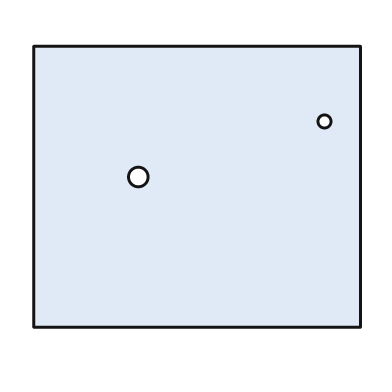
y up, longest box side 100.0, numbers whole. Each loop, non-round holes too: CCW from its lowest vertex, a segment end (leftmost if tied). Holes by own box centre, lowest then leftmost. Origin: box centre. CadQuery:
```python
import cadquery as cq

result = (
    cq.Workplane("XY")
    .moveTo(-50.0, -43.0)
    .lineTo(50.0, -43.0)
    .lineTo(50.0, 43.0)
    .lineTo(-50.0, 43.0)
    .close()
    .moveTo(-18.0, 3.0)
    .circle(3.0)
    .moveTo(39.0, 20.0)
    .circle(2.0)
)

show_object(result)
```